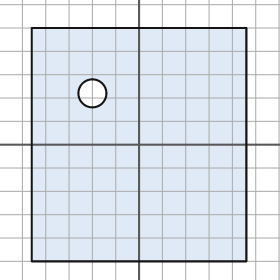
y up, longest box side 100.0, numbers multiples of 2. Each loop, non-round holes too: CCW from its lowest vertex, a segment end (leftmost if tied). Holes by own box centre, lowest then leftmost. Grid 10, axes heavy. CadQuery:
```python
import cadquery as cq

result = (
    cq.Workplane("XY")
    .moveTo(-46.0, -50.0)
    .lineTo(46.0, -50.0)
    .lineTo(46.0, 50.0)
    .lineTo(-46.0, 50.0)
    .close()
    .moveTo(-20.0, 22.0)
    .circle(6.0)
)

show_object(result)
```